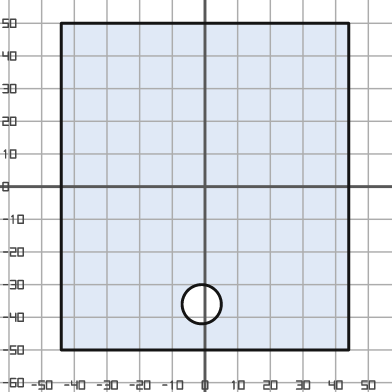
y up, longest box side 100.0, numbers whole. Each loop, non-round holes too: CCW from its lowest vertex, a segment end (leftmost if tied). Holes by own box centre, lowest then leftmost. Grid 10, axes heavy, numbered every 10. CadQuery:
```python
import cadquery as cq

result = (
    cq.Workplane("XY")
    .moveTo(-44.0, -50.0)
    .lineTo(44.0, -50.0)
    .lineTo(44.0, 50.0)
    .lineTo(-44.0, 50.0)
    .close()
    .moveTo(-1.0, -36.0)
    .circle(6.0)
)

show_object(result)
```